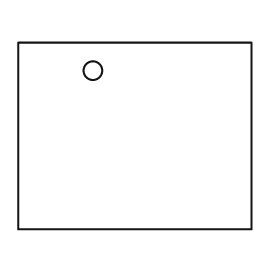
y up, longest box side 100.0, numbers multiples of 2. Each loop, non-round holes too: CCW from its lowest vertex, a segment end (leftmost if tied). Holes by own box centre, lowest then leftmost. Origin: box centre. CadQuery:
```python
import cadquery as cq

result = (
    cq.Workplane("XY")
    .moveTo(-50.0, -40.0)
    .lineTo(50.0, -40.0)
    .lineTo(50.0, 40.0)
    .lineTo(-50.0, 40.0)
    .close()
    .moveTo(-18.0, 28.0)
    .circle(4.0)
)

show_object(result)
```